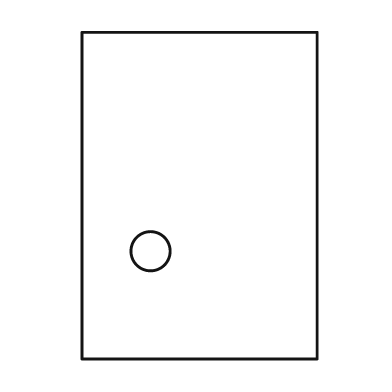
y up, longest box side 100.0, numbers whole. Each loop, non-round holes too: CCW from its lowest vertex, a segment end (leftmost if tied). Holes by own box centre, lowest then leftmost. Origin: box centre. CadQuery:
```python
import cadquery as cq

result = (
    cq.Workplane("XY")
    .moveTo(-36.0, -50.0)
    .lineTo(36.0, -50.0)
    .lineTo(36.0, 50.0)
    .lineTo(-36.0, 50.0)
    .close()
    .moveTo(-15.0, -17.0)
    .circle(6.0)
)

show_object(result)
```